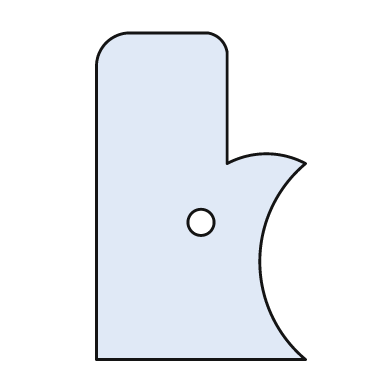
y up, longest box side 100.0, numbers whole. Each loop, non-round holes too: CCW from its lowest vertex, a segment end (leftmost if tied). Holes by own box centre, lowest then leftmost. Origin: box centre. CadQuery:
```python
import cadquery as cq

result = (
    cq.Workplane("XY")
    .moveTo(-32.0, -50.0)
    .lineTo(32.0, -50.0)
    .threePointArc((18.0, -20.0), (32.0, 10.0))
    .threePointArc((20.0, 13.0), (8.0, 10.0))
    .lineTo(8.0, 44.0)
    .threePointArc((6.0, 48.0), (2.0, 50.0))
    .lineTo(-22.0, 50.0)
    .threePointArc((-29.0, 47.0), (-32.0, 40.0))
    .close()
    .moveTo(0.0, -8.0)
    .circle(4.0)
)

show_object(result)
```